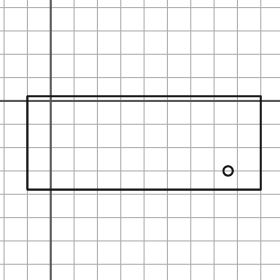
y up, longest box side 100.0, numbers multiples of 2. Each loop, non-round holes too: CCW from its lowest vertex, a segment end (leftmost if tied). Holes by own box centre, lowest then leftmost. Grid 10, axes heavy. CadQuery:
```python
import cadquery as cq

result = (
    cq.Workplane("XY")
    .moveTo(-10.0, -38.0)
    .lineTo(90.0, -38.0)
    .lineTo(90.0, 2.0)
    .lineTo(-10.0, 2.0)
    .close()
    .moveTo(76.0, -30.0)
    .circle(2.0)
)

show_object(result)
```